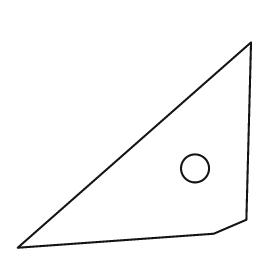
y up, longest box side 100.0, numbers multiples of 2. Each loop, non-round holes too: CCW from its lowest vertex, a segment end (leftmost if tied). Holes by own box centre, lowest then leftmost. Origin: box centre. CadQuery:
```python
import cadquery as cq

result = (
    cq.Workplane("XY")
    .moveTo(-50.0, -44.0)
    .lineTo(34.0, -38.0)
    .lineTo(48.0, -32.0)
    .lineTo(50.0, 44.0)
    .close()
    .moveTo(26.0, -10.0)
    .circle(6.0)
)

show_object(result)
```